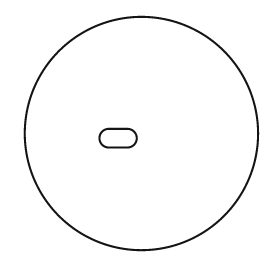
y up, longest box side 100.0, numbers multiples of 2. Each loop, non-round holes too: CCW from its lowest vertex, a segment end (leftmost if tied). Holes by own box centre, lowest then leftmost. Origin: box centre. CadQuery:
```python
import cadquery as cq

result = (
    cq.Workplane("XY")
    .moveTo(0.0, 0.0)
    .circle(50.0)
    .moveTo(-14.0, -6.0)
    .lineTo(-6.0, -6.0)
    .threePointArc((-2.0, -2.0), (-6.0, 2.0))
    .lineTo(-14.0, 2.0)
    .threePointArc((-18.0, -2.0), (-14.0, -6.0))
    .close()
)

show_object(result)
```